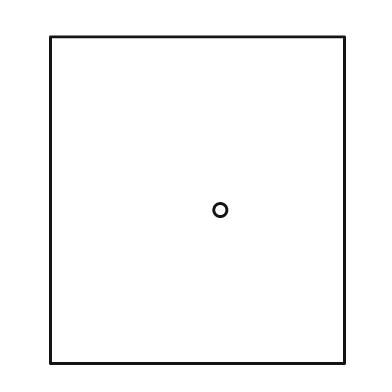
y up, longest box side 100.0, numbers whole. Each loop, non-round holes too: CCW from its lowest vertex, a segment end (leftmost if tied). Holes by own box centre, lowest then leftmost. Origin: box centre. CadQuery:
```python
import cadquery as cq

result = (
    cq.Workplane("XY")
    .moveTo(-45.0, -50.0)
    .lineTo(45.0, -50.0)
    .lineTo(45.0, 50.0)
    .lineTo(-45.0, 50.0)
    .close()
    .moveTo(7.0, -3.0)
    .circle(2.0)
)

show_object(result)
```